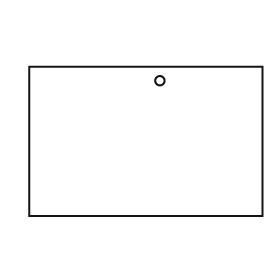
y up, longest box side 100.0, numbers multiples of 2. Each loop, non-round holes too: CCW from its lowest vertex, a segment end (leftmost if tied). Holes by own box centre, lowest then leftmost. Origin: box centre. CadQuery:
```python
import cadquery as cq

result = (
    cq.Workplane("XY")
    .moveTo(-50.0, -32.0)
    .lineTo(50.0, -32.0)
    .lineTo(50.0, 32.0)
    .lineTo(-50.0, 32.0)
    .close()
    .moveTo(6.0, 26.0)
    .circle(2.0)
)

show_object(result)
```